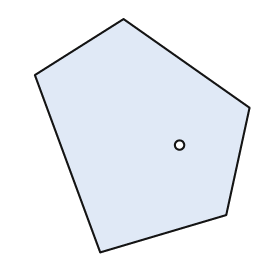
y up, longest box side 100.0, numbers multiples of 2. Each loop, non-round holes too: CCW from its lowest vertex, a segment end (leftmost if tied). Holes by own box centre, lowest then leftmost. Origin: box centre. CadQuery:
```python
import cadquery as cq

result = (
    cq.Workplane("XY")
    .moveTo(-18.0, -50.0)
    .lineTo(36.0, -34.0)
    .lineTo(46.0, 12.0)
    .lineTo(-8.0, 50.0)
    .lineTo(-46.0, 26.0)
    .close()
    .moveTo(16.0, -4.0)
    .circle(2.0)
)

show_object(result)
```